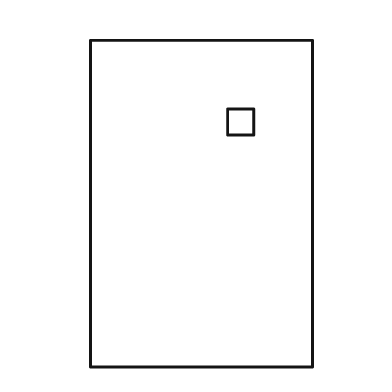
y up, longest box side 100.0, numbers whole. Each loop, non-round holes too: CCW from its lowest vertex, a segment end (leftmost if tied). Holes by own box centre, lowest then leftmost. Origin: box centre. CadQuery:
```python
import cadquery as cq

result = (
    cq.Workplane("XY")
    .moveTo(-34.0, -50.0)
    .lineTo(34.0, -50.0)
    .lineTo(34.0, 50.0)
    .lineTo(-34.0, 50.0)
    .close()
    .moveTo(8.0, 21.0)
    .lineTo(16.0, 21.0)
    .lineTo(16.0, 29.0)
    .lineTo(8.0, 29.0)
    .close()
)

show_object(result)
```